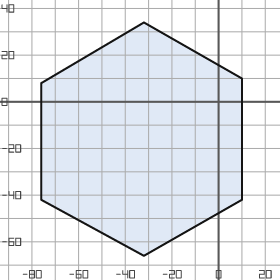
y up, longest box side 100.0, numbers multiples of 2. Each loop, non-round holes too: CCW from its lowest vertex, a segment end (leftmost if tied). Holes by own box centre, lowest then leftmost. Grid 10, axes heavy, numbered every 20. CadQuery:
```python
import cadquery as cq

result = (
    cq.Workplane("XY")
    .moveTo(-32.0, -66.0)
    .lineTo(10.0, -42.0)
    .lineTo(10.0, 10.0)
    .lineTo(-32.0, 34.0)
    .lineTo(-76.0, 8.0)
    .lineTo(-76.0, -42.0)
    .close()
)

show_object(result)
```